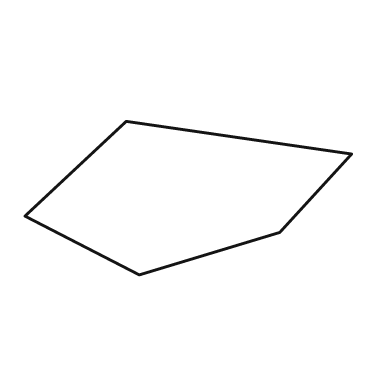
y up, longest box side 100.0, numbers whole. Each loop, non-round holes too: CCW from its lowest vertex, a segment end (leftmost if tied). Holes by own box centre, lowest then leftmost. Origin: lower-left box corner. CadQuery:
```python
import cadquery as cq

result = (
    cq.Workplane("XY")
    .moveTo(35.0, 0.0)
    .lineTo(78.0, 13.0)
    .lineTo(100.0, 37.0)
    .lineTo(31.0, 47.0)
    .lineTo(0.0, 18.0)
    .close()
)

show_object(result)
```